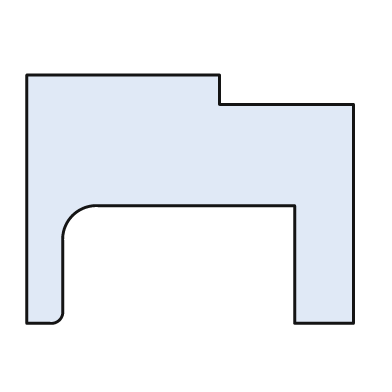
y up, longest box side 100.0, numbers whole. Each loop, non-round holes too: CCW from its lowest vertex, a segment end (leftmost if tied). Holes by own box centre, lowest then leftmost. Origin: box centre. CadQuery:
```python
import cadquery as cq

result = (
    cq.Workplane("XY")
    .moveTo(-50.0, -38.0)
    .lineTo(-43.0, -38.0)
    .threePointArc((-40.0, -37.0), (-39.0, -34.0))
    .lineTo(-39.0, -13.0)
    .threePointArc((-36.0, -5.0), (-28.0, -2.0))
    .lineTo(32.0, -2.0)
    .lineTo(32.0, -38.0)
    .lineTo(50.0, -38.0)
    .lineTo(50.0, 29.0)
    .lineTo(9.0, 29.0)
    .lineTo(9.0, 38.0)
    .lineTo(-50.0, 38.0)
    .close()
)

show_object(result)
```